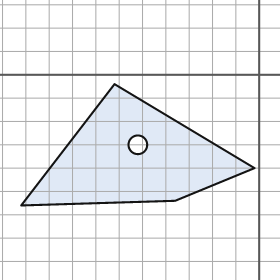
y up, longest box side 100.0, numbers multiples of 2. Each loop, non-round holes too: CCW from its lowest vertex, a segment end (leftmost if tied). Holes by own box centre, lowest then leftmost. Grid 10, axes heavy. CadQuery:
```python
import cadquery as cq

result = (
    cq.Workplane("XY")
    .moveTo(-102.0, -56.0)
    .lineTo(-36.0, -54.0)
    .lineTo(-2.0, -40.0)
    .lineTo(-62.0, -4.0)
    .close()
    .moveTo(-52.0, -30.0)
    .circle(4.0)
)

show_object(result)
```